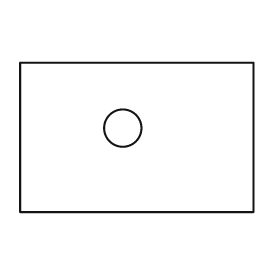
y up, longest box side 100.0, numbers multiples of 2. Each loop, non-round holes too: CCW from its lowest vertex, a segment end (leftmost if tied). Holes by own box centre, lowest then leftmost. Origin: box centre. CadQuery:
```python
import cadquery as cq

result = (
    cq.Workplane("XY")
    .moveTo(-50.0, -32.0)
    .lineTo(50.0, -32.0)
    .lineTo(50.0, 32.0)
    .lineTo(-50.0, 32.0)
    .close()
    .moveTo(-6.0, 4.0)
    .circle(8.0)
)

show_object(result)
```